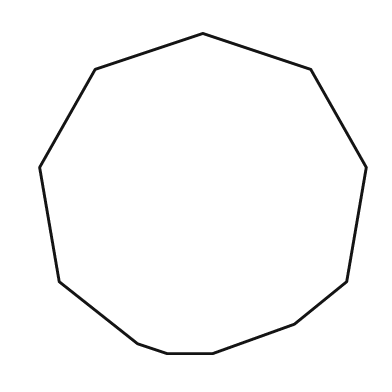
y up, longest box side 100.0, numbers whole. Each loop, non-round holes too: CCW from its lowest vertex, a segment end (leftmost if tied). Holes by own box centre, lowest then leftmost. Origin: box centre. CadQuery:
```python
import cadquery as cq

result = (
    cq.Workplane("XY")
    .moveTo(-11.0, -49.0)
    .lineTo(3.0, -49.0)
    .lineTo(28.0, -40.0)
    .lineTo(44.0, -27.0)
    .lineTo(50.0, 8.0)
    .lineTo(33.0, 38.0)
    .lineTo(0.0, 49.0)
    .lineTo(-33.0, 38.0)
    .lineTo(-50.0, 8.0)
    .lineTo(-44.0, -27.0)
    .lineTo(-20.0, -46.0)
    .close()
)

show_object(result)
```